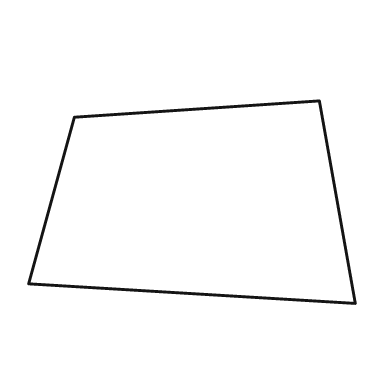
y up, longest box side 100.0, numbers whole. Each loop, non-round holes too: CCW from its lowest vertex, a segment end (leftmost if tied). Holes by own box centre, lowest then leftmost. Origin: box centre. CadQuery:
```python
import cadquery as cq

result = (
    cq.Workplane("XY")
    .moveTo(50.0, -31.0)
    .lineTo(39.0, 31.0)
    .lineTo(-36.0, 26.0)
    .lineTo(-50.0, -25.0)
    .close()
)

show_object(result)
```